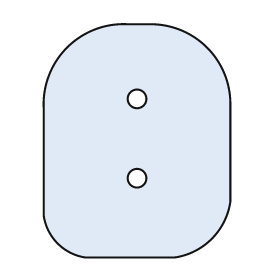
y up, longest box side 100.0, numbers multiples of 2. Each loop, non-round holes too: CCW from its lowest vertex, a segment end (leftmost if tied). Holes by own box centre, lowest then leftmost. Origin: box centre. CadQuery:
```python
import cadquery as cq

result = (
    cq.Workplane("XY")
    .moveTo(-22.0, -50.0)
    .lineTo(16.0, -50.0)
    .threePointArc((32.0, -42.0), (40.0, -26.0))
    .lineTo(40.0, 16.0)
    .threePointArc((30.0, 40.0), (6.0, 50.0))
    .lineTo(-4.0, 50.0)
    .threePointArc((-30.0, 40.0), (-40.0, 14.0))
    .lineTo(-40.0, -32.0)
    .threePointArc((-34.0, -44.0), (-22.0, -50.0))
    .close()
    .moveTo(0.0, -16.0)
    .circle(4.0)
    .moveTo(0.0, 18.0)
    .circle(4.0)
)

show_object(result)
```